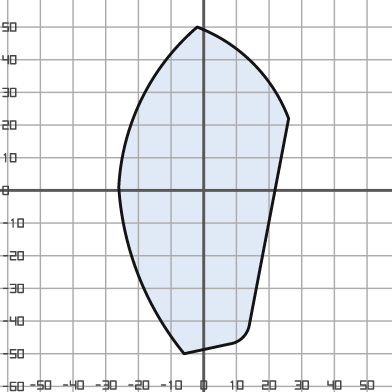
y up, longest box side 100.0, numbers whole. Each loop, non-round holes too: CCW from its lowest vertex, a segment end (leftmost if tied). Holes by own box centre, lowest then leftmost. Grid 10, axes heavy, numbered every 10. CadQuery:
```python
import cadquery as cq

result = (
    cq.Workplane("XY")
    .moveTo(-6.0, -50.0)
    .lineTo(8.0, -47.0)
    .threePointArc((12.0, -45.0), (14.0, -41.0))
    .lineTo(26.0, 22.0)
    .threePointArc((15.0, 39.0), (-2.0, 50.0))
    .threePointArc((-19.0, 28.0), (-26.0, 1.0))
    .threePointArc((-20.0, -26.0), (-6.0, -50.0))
    .close()
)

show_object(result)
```